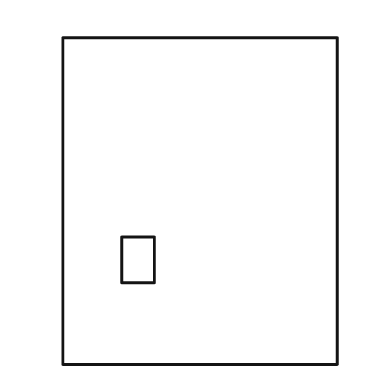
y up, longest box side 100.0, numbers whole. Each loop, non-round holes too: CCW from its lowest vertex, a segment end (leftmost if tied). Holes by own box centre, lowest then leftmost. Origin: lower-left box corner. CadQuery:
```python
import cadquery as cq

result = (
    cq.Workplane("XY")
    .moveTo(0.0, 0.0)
    .lineTo(84.0, 0.0)
    .lineTo(84.0, 100.0)
    .lineTo(0.0, 100.0)
    .close()
    .moveTo(18.0, 25.0)
    .lineTo(28.0, 25.0)
    .lineTo(28.0, 39.0)
    .lineTo(18.0, 39.0)
    .close()
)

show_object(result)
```